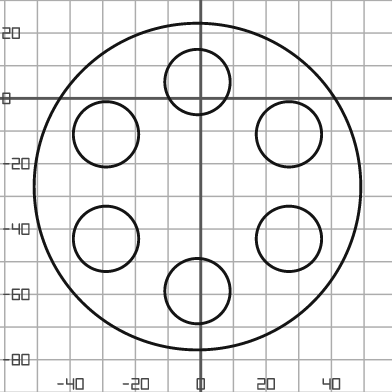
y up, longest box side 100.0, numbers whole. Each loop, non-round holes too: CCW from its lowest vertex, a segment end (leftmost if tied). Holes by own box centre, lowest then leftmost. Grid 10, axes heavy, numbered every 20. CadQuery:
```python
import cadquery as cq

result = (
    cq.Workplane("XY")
    .moveTo(-1.0, -27.0)
    .circle(50.0)
    .moveTo(-1.0, -59.0)
    .circle(10.0)
    .moveTo(-29.0, -43.0)
    .circle(10.0)
    .moveTo(27.0, -43.0)
    .circle(10.0)
    .moveTo(-29.0, -11.0)
    .circle(10.0)
    .moveTo(27.0, -11.0)
    .circle(10.0)
    .moveTo(-1.0, 5.0)
    .circle(10.0)
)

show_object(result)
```